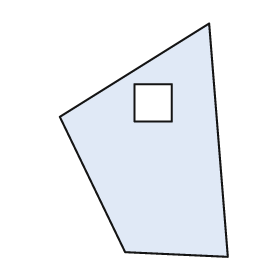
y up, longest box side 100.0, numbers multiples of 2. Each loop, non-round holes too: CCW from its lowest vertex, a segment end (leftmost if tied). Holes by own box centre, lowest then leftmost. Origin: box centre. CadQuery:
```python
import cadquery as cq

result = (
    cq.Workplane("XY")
    .moveTo(36.0, -50.0)
    .lineTo(28.0, 50.0)
    .lineTo(-36.0, 10.0)
    .lineTo(-8.0, -48.0)
    .close()
    .moveTo(-4.0, 8.0)
    .lineTo(12.0, 8.0)
    .lineTo(12.0, 24.0)
    .lineTo(-4.0, 24.0)
    .close()
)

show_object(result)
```